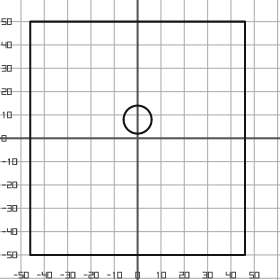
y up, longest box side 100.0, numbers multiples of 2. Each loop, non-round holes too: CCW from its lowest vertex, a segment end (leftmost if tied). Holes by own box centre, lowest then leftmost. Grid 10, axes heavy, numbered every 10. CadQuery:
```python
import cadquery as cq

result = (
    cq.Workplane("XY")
    .moveTo(-46.0, -50.0)
    .lineTo(46.0, -50.0)
    .lineTo(46.0, 50.0)
    .lineTo(-46.0, 50.0)
    .close()
    .moveTo(0.0, 8.0)
    .circle(6.0)
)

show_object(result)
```